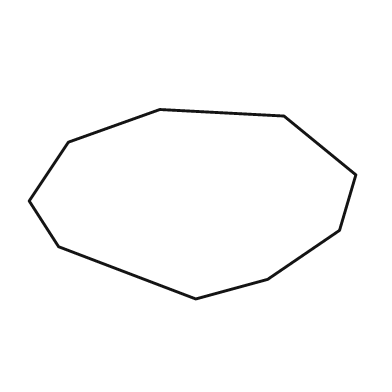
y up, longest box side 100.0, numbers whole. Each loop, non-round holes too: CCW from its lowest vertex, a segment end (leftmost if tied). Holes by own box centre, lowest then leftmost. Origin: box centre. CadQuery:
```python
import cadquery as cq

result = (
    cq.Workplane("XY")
    .moveTo(1.0, -29.0)
    .lineTo(23.0, -23.0)
    .lineTo(45.0, -8.0)
    .lineTo(50.0, 9.0)
    .lineTo(28.0, 27.0)
    .lineTo(-10.0, 29.0)
    .lineTo(-38.0, 19.0)
    .lineTo(-50.0, 1.0)
    .lineTo(-41.0, -13.0)
    .close()
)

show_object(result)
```